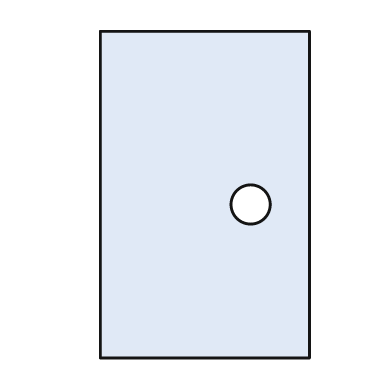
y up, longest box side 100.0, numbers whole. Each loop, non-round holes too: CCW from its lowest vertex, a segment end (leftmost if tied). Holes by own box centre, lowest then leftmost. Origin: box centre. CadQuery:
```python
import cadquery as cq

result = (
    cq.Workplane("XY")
    .moveTo(-32.0, -50.0)
    .lineTo(32.0, -50.0)
    .lineTo(32.0, 50.0)
    .lineTo(-32.0, 50.0)
    .close()
    .moveTo(14.0, -3.0)
    .circle(6.0)
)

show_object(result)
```